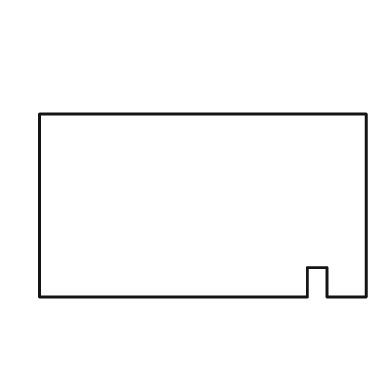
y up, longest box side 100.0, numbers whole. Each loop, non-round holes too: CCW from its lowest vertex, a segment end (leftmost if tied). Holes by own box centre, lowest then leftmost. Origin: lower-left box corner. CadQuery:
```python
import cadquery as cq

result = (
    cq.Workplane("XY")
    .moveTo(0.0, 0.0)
    .lineTo(82.0, 0.0)
    .lineTo(82.0, 9.0)
    .lineTo(88.0, 9.0)
    .lineTo(88.0, 0.0)
    .lineTo(100.0, 0.0)
    .lineTo(100.0, 56.0)
    .lineTo(0.0, 56.0)
    .close()
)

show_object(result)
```